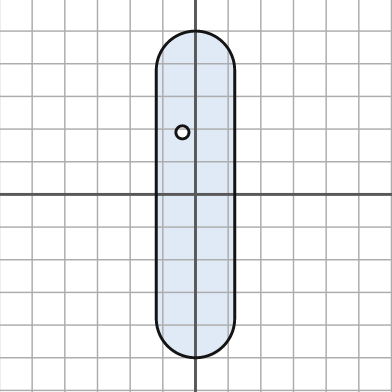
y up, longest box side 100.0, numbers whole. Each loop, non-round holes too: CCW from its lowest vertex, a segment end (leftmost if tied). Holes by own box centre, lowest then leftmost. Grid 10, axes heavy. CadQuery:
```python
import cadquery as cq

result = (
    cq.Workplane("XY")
    .moveTo(-12.0, -38.0)
    .threePointArc((0.0, -50.0), (12.0, -38.0))
    .lineTo(12.0, 38.0)
    .threePointArc((0.0, 50.0), (-12.0, 38.0))
    .close()
    .moveTo(-4.0, 19.0)
    .circle(2.0)
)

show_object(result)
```